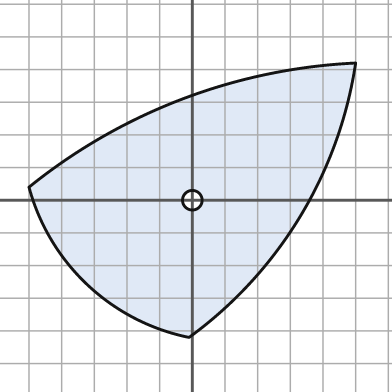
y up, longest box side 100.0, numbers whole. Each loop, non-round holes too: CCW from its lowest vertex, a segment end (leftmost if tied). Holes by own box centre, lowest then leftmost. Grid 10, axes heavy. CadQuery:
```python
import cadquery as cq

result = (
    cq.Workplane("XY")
    .moveTo(-1.0, -42.0)
    .threePointArc((33.0, -5.0), (50.0, 42.0))
    .threePointArc((-3.0, 31.0), (-50.0, 4.0))
    .threePointArc((-32.0, -26.0), (-1.0, -42.0))
    .close()
    .moveTo(0.0, 0.0)
    .circle(3.0)
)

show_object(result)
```